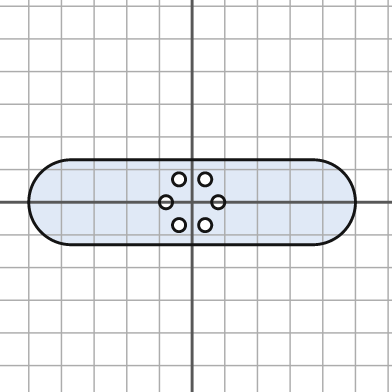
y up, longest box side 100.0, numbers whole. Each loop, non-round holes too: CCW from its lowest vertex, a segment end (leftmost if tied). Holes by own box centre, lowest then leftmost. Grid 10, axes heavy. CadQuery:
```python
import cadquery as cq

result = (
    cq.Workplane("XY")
    .moveTo(-37.0, -13.0)
    .lineTo(37.0, -13.0)
    .threePointArc((50.0, 0.0), (37.0, 13.0))
    .lineTo(-37.0, 13.0)
    .threePointArc((-50.0, 0.0), (-37.0, -13.0))
    .close()
    .moveTo(-4.0, -7.0)
    .circle(2.0)
    .moveTo(4.0, -7.0)
    .circle(2.0)
    .moveTo(-8.0, 0.0)
    .circle(2.0)
    .moveTo(8.0, 0.0)
    .circle(2.0)
    .moveTo(-4.0, 7.0)
    .circle(2.0)
    .moveTo(4.0, 7.0)
    .circle(2.0)
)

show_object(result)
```